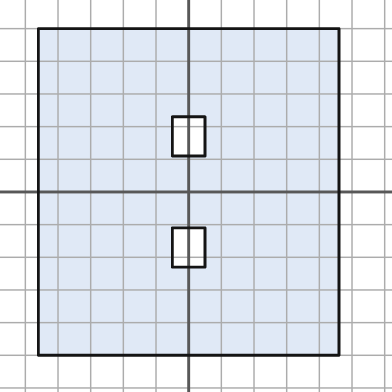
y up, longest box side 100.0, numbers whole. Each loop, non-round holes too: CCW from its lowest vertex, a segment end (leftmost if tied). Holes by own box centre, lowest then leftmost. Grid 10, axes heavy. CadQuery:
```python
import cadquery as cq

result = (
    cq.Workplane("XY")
    .moveTo(-46.0, -50.0)
    .lineTo(46.0, -50.0)
    .lineTo(46.0, 50.0)
    .lineTo(-46.0, 50.0)
    .close()
    .moveTo(-5.0, -23.0)
    .lineTo(5.0, -23.0)
    .lineTo(5.0, -11.0)
    .lineTo(-5.0, -11.0)
    .close()
    .moveTo(-5.0, 11.0)
    .lineTo(5.0, 11.0)
    .lineTo(5.0, 23.0)
    .lineTo(-5.0, 23.0)
    .close()
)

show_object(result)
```